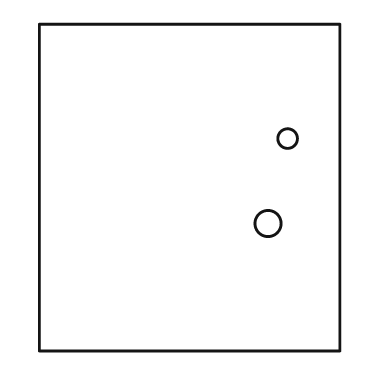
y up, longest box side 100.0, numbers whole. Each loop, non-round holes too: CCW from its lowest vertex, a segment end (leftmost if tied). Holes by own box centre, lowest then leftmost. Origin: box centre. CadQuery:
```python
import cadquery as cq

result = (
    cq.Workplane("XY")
    .moveTo(-46.0, -50.0)
    .lineTo(46.0, -50.0)
    .lineTo(46.0, 50.0)
    .lineTo(-46.0, 50.0)
    .close()
    .moveTo(24.0, -11.0)
    .circle(4.0)
    .moveTo(30.0, 15.0)
    .circle(3.0)
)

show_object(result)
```